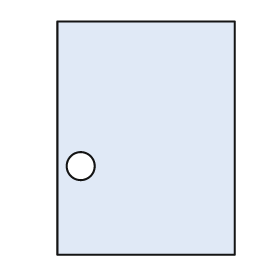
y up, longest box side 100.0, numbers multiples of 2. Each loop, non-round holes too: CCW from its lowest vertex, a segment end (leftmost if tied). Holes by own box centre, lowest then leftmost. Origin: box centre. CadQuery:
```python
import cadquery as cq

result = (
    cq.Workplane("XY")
    .moveTo(-38.0, -50.0)
    .lineTo(38.0, -50.0)
    .lineTo(38.0, 50.0)
    .lineTo(-38.0, 50.0)
    .close()
    .moveTo(-28.0, -12.0)
    .circle(6.0)
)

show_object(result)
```